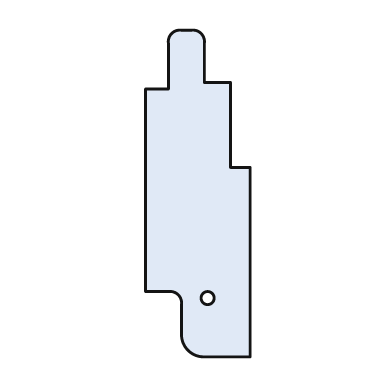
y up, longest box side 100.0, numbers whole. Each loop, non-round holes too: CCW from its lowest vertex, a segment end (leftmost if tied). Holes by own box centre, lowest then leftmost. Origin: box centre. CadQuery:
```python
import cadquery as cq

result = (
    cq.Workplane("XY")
    .moveTo(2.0, -50.0)
    .lineTo(16.0, -50.0)
    .lineTo(16.0, 8.0)
    .lineTo(10.0, 8.0)
    .lineTo(10.0, 34.0)
    .lineTo(2.0, 34.0)
    .lineTo(2.0, 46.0)
    .threePointArc((1.0, 49.0), (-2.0, 50.0))
    .lineTo(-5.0, 50.0)
    .threePointArc((-8.0, 49.0), (-9.0, 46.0))
    .lineTo(-9.0, 32.0)
    .lineTo(-16.0, 32.0)
    .lineTo(-16.0, -30.0)
    .lineTo(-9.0, -30.0)
    .threePointArc((-6.0, -31.0), (-5.0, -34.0))
    .lineTo(-5.0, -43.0)
    .threePointArc((-3.0, -48.0), (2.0, -50.0))
    .close()
    .moveTo(3.0, -32.0)
    .circle(2.0)
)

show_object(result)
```